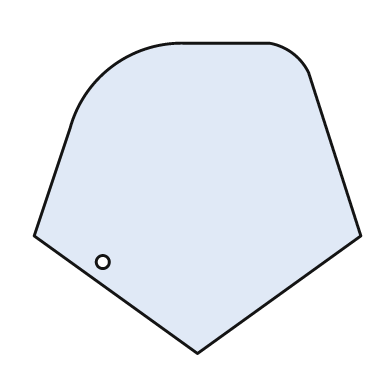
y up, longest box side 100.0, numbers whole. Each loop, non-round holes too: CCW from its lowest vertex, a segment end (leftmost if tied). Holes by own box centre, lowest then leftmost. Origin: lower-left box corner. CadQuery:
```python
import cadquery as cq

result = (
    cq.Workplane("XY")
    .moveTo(50.0, 0.0)
    .lineTo(100.0, 36.0)
    .lineTo(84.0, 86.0)
    .threePointArc((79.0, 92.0), (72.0, 95.0))
    .lineTo(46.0, 95.0)
    .threePointArc((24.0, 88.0), (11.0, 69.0))
    .lineTo(0.0, 36.0)
    .close()
    .moveTo(21.0, 28.0)
    .circle(2.0)
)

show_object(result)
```